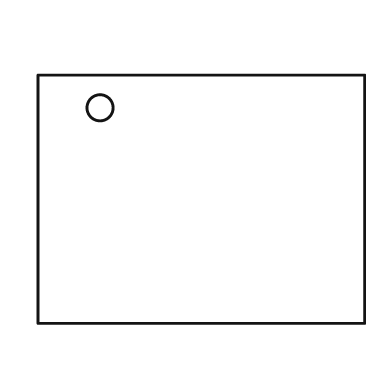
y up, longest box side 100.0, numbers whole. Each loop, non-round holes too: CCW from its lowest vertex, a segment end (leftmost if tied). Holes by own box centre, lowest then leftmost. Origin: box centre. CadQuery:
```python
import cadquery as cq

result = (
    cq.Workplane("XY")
    .moveTo(-50.0, -38.0)
    .lineTo(50.0, -38.0)
    .lineTo(50.0, 38.0)
    .lineTo(-50.0, 38.0)
    .close()
    .moveTo(-31.0, 28.0)
    .circle(4.0)
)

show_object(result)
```